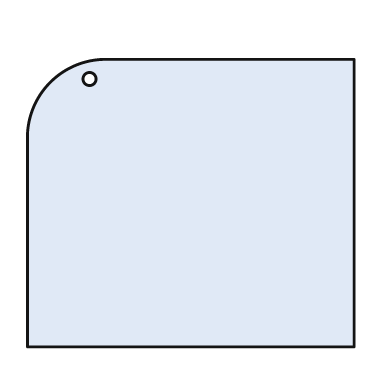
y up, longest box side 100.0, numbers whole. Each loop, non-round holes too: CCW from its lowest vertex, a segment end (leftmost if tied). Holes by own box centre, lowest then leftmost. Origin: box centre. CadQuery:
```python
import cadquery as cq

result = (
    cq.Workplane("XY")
    .moveTo(-50.0, -44.0)
    .lineTo(50.0, -44.0)
    .lineTo(50.0, 44.0)
    .lineTo(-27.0, 44.0)
    .threePointArc((-43.0, 37.0), (-50.0, 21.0))
    .close()
    .moveTo(-31.0, 38.0)
    .circle(2.0)
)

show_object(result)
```